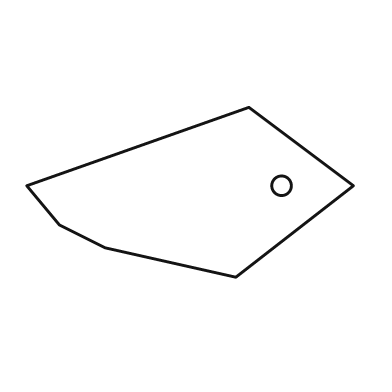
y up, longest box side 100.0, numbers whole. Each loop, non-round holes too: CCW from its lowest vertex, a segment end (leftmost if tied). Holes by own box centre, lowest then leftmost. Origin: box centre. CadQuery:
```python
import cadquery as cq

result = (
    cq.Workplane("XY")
    .moveTo(14.0, -26.0)
    .lineTo(50.0, 2.0)
    .lineTo(18.0, 26.0)
    .lineTo(-50.0, 2.0)
    .lineTo(-40.0, -10.0)
    .lineTo(-26.0, -17.0)
    .close()
    .moveTo(28.0, 2.0)
    .circle(3.0)
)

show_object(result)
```